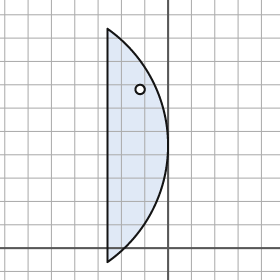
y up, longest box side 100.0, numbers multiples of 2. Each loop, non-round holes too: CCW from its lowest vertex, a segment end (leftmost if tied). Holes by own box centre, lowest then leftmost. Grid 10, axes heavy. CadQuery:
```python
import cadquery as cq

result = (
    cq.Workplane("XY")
    .moveTo(-26.0, -6.0)
    .threePointArc((0.0, 44.0), (-26.0, 94.0))
    .close()
    .moveTo(-12.0, 68.0)
    .circle(2.0)
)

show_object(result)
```